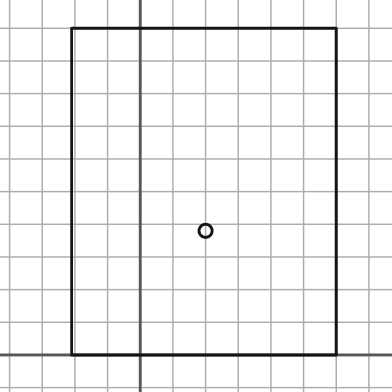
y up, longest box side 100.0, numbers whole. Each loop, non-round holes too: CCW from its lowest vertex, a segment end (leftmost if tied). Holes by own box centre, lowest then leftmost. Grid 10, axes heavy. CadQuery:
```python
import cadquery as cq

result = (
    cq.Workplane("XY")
    .moveTo(-21.0, 0.0)
    .lineTo(60.0, 0.0)
    .lineTo(60.0, 100.0)
    .lineTo(-21.0, 100.0)
    .close()
    .moveTo(20.0, 38.0)
    .circle(2.0)
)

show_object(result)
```